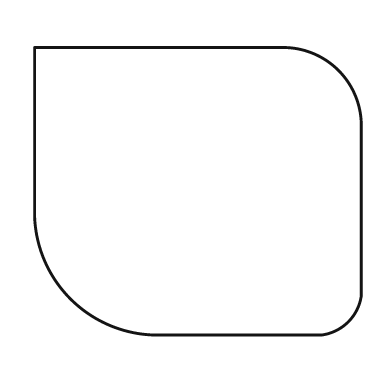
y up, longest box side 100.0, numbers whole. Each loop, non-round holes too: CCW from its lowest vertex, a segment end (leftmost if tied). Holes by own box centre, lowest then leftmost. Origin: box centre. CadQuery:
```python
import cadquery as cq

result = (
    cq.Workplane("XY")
    .moveTo(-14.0, -44.0)
    .lineTo(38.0, -44.0)
    .threePointArc((46.0, -40.0), (50.0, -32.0))
    .lineTo(50.0, 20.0)
    .threePointArc((43.0, 37.0), (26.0, 44.0))
    .lineTo(-50.0, 44.0)
    .lineTo(-50.0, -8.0)
    .threePointArc((-39.0, -33.0), (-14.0, -44.0))
    .close()
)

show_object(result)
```